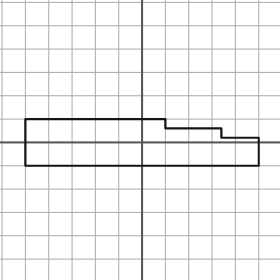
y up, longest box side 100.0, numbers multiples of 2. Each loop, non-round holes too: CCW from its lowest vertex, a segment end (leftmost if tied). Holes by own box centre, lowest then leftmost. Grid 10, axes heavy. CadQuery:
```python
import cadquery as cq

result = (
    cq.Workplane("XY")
    .moveTo(-50.0, -10.0)
    .lineTo(50.0, -10.0)
    .lineTo(50.0, 2.0)
    .lineTo(34.0, 2.0)
    .lineTo(34.0, 6.0)
    .lineTo(10.0, 6.0)
    .lineTo(10.0, 10.0)
    .lineTo(-50.0, 10.0)
    .close()
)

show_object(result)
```